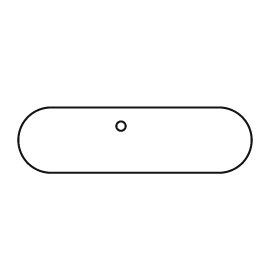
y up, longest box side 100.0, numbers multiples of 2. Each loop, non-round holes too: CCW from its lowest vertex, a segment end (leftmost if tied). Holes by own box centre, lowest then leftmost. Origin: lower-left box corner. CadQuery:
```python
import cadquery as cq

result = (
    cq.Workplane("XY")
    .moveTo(14.0, 0.0)
    .lineTo(86.0, 0.0)
    .threePointArc((100.0, 14.0), (86.0, 28.0))
    .lineTo(14.0, 28.0)
    .threePointArc((0.0, 14.0), (14.0, 0.0))
    .close()
    .moveTo(44.0, 20.0)
    .circle(2.0)
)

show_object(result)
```